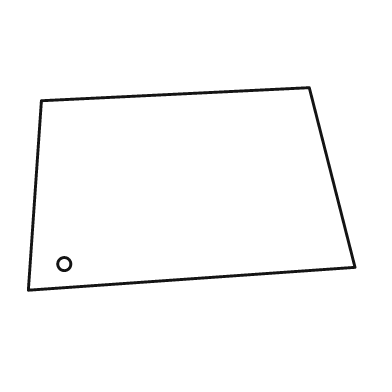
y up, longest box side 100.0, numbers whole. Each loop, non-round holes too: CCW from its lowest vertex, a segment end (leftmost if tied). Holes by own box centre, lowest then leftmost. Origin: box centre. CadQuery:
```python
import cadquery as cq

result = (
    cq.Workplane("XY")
    .moveTo(-50.0, -31.0)
    .lineTo(50.0, -24.0)
    .lineTo(36.0, 31.0)
    .lineTo(-46.0, 27.0)
    .close()
    .moveTo(-39.0, -23.0)
    .circle(2.0)
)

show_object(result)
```